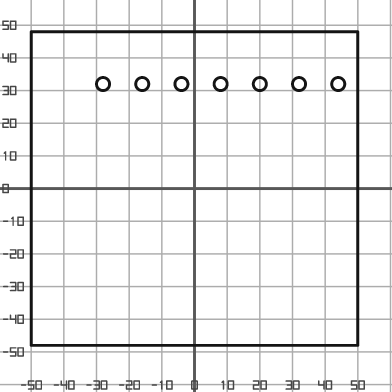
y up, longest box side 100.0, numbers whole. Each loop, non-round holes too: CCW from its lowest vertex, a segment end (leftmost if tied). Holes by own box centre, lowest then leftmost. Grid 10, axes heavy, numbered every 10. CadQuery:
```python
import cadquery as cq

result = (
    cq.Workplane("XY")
    .moveTo(-50.0, -48.0)
    .lineTo(50.0, -48.0)
    .lineTo(50.0, 48.0)
    .lineTo(-50.0, 48.0)
    .close()
    .moveTo(-28.0, 32.0)
    .circle(2.0)
    .moveTo(-16.0, 32.0)
    .circle(2.0)
    .moveTo(-4.0, 32.0)
    .circle(2.0)
    .moveTo(8.0, 32.0)
    .circle(2.0)
    .moveTo(20.0, 32.0)
    .circle(2.0)
    .moveTo(32.0, 32.0)
    .circle(2.0)
    .moveTo(44.0, 32.0)
    .circle(2.0)
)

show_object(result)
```